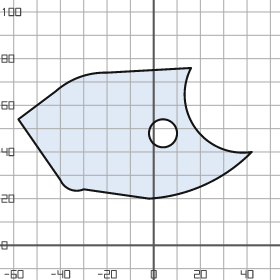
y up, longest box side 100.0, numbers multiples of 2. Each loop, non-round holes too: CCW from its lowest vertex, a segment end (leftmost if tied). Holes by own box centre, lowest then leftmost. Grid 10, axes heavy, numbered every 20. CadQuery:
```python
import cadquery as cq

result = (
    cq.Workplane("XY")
    .moveTo(-2.0, 20.0)
    .threePointArc((22.0, 26.0), (42.0, 40.0))
    .threePointArc((18.0, 50.0), (16.0, 76.0))
    .lineTo(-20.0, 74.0)
    .threePointArc((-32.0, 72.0), (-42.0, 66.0))
    .lineTo(-58.0, 54.0)
    .lineTo(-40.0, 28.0)
    .threePointArc((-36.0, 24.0), (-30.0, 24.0))
    .close()
    .moveTo(4.0, 48.0)
    .circle(6.0)
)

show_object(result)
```